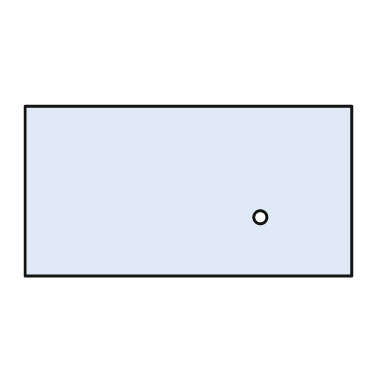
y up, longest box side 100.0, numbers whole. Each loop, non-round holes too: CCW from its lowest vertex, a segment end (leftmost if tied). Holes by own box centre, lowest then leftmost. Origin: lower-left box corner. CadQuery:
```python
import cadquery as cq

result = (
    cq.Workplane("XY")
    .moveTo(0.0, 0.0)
    .lineTo(100.0, 0.0)
    .lineTo(100.0, 52.0)
    .lineTo(0.0, 52.0)
    .close()
    .moveTo(72.0, 18.0)
    .circle(2.0)
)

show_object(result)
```